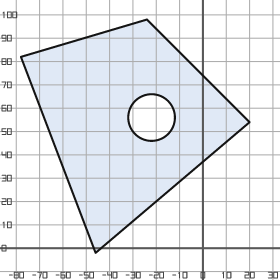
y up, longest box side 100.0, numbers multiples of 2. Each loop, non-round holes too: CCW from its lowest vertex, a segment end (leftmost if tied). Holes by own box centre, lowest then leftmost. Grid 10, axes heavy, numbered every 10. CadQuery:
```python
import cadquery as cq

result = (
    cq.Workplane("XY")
    .moveTo(-46.0, -2.0)
    .lineTo(20.0, 54.0)
    .lineTo(-24.0, 98.0)
    .lineTo(-78.0, 82.0)
    .close()
    .moveTo(-22.0, 56.0)
    .circle(10.0)
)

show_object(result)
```